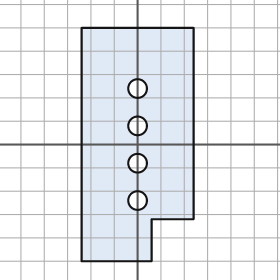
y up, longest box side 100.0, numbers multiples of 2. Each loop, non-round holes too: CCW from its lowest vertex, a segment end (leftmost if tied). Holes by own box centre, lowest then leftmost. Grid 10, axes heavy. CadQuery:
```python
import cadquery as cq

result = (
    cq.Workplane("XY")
    .moveTo(-24.0, -50.0)
    .lineTo(6.0, -50.0)
    .lineTo(6.0, -32.0)
    .lineTo(24.0, -32.0)
    .lineTo(24.0, 50.0)
    .lineTo(-24.0, 50.0)
    .close()
    .moveTo(0.0, -24.0)
    .circle(4.0)
    .moveTo(0.0, -8.0)
    .circle(4.0)
    .moveTo(0.0, 8.0)
    .circle(4.0)
    .moveTo(0.0, 24.0)
    .circle(4.0)
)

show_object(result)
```